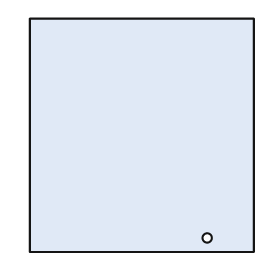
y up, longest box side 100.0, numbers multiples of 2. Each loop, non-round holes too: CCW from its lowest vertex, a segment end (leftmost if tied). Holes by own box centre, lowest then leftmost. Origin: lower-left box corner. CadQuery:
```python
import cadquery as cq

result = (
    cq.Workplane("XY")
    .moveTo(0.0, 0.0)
    .lineTo(96.0, 0.0)
    .lineTo(96.0, 100.0)
    .lineTo(0.0, 100.0)
    .close()
    .moveTo(76.0, 6.0)
    .circle(2.0)
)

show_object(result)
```